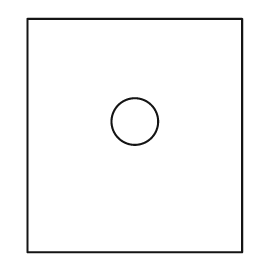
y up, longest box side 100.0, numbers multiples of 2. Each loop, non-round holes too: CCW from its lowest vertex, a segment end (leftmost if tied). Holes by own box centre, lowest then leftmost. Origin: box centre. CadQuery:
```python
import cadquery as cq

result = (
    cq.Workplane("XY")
    .moveTo(-46.0, -50.0)
    .lineTo(46.0, -50.0)
    .lineTo(46.0, 50.0)
    .lineTo(-46.0, 50.0)
    .close()
    .moveTo(0.0, 6.0)
    .circle(10.0)
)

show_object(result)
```